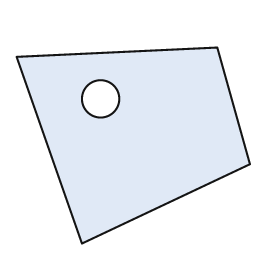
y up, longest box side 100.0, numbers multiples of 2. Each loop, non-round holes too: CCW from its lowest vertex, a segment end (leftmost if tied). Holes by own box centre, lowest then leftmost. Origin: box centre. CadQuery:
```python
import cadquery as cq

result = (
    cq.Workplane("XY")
    .moveTo(-22.0, -42.0)
    .lineTo(50.0, -8.0)
    .lineTo(36.0, 42.0)
    .lineTo(-50.0, 38.0)
    .close()
    .moveTo(-14.0, 20.0)
    .circle(8.0)
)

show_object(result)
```